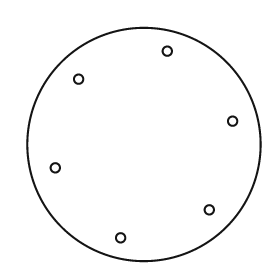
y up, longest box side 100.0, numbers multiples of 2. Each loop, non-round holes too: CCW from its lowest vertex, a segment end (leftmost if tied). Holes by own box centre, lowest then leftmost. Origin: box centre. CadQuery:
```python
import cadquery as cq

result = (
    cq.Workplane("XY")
    .moveTo(0.0, 0.0)
    .circle(50.0)
    .moveTo(-10.0, -40.0)
    .circle(2.0)
    .moveTo(28.0, -28.0)
    .circle(2.0)
    .moveTo(-38.0, -10.0)
    .circle(2.0)
    .moveTo(38.0, 10.0)
    .circle(2.0)
    .moveTo(-28.0, 28.0)
    .circle(2.0)
    .moveTo(10.0, 40.0)
    .circle(2.0)
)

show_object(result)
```